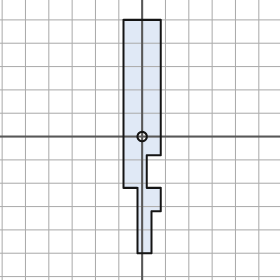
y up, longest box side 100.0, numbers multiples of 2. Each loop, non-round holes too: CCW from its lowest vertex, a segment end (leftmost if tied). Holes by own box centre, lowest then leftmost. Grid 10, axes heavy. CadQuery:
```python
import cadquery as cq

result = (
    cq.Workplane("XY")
    .moveTo(-2.0, -50.0)
    .lineTo(4.0, -50.0)
    .lineTo(4.0, -32.0)
    .lineTo(8.0, -32.0)
    .lineTo(8.0, -22.0)
    .lineTo(2.0, -22.0)
    .lineTo(2.0, -8.0)
    .lineTo(8.0, -8.0)
    .lineTo(8.0, 50.0)
    .lineTo(-8.0, 50.0)
    .lineTo(-8.0, -22.0)
    .lineTo(-2.0, -22.0)
    .close()
    .moveTo(0.0, 0.0)
    .circle(2.0)
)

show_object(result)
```